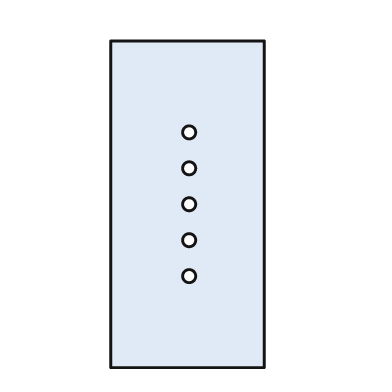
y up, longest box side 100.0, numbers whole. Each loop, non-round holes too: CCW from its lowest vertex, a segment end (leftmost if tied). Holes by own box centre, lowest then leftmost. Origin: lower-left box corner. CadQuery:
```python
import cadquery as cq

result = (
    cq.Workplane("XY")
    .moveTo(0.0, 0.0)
    .lineTo(47.0, 0.0)
    .lineTo(47.0, 100.0)
    .lineTo(0.0, 100.0)
    .close()
    .moveTo(24.0, 28.0)
    .circle(2.0)
    .moveTo(24.0, 39.0)
    .circle(2.0)
    .moveTo(24.0, 50.0)
    .circle(2.0)
    .moveTo(24.0, 61.0)
    .circle(2.0)
    .moveTo(24.0, 72.0)
    .circle(2.0)
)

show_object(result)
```